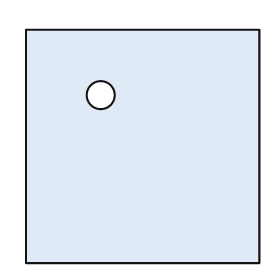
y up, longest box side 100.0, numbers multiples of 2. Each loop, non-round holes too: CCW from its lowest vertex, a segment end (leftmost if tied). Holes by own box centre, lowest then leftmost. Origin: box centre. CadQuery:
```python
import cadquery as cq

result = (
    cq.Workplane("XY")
    .moveTo(-50.0, -50.0)
    .lineTo(50.0, -50.0)
    .lineTo(50.0, 50.0)
    .lineTo(-50.0, 50.0)
    .close()
    .moveTo(-18.0, 22.0)
    .circle(6.0)
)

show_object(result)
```